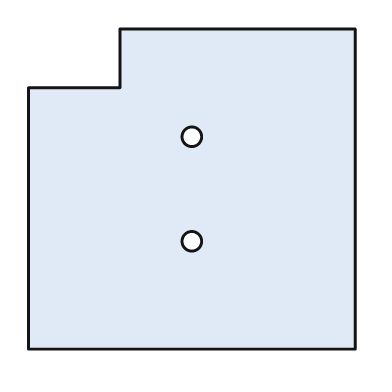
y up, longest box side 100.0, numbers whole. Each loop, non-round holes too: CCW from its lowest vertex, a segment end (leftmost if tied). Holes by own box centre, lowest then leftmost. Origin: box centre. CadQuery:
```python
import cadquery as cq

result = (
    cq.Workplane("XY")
    .moveTo(-50.0, -49.0)
    .lineTo(50.0, -49.0)
    .lineTo(50.0, 49.0)
    .lineTo(-22.0, 49.0)
    .lineTo(-22.0, 31.0)
    .lineTo(-50.0, 31.0)
    .close()
    .moveTo(0.0, -16.0)
    .circle(3.0)
    .moveTo(0.0, 16.0)
    .circle(3.0)
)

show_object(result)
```